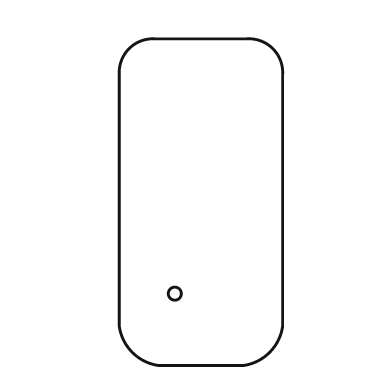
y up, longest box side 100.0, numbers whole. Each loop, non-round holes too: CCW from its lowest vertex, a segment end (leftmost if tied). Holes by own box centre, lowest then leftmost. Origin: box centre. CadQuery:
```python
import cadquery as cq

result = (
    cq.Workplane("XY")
    .moveTo(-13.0, -50.0)
    .lineTo(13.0, -50.0)
    .threePointArc((21.0, -46.0), (25.0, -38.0))
    .lineTo(25.0, 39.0)
    .threePointArc((22.0, 47.0), (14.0, 50.0))
    .lineTo(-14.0, 50.0)
    .threePointArc((-22.0, 47.0), (-25.0, 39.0))
    .lineTo(-25.0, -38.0)
    .threePointArc((-21.0, -46.0), (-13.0, -50.0))
    .close()
    .moveTo(-8.0, -28.0)
    .circle(2.0)
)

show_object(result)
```